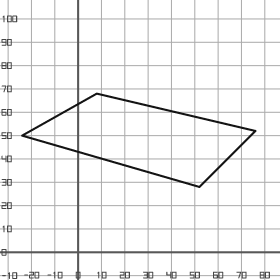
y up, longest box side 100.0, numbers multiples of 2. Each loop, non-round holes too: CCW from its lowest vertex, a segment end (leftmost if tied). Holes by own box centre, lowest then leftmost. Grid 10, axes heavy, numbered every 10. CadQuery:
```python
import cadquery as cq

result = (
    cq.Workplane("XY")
    .moveTo(52.0, 28.0)
    .lineTo(76.0, 52.0)
    .lineTo(8.0, 68.0)
    .lineTo(-24.0, 50.0)
    .close()
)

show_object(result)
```